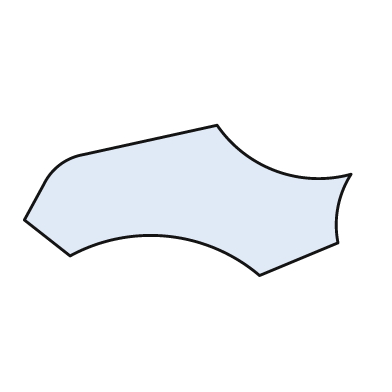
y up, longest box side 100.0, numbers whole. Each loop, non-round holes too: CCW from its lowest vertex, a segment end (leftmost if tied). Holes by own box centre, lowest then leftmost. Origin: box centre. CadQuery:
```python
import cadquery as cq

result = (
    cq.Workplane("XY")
    .moveTo(22.0, -23.0)
    .lineTo(46.0, -13.0)
    .threePointArc((46.0, -2.0), (50.0, 8.0))
    .threePointArc((27.0, 9.0), (9.0, 23.0))
    .lineTo(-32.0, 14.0)
    .threePointArc((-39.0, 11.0), (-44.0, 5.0))
    .lineTo(-50.0, -6.0)
    .lineTo(-36.0, -17.0)
    .threePointArc((-6.0, -11.0), (22.0, -23.0))
    .close()
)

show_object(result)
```